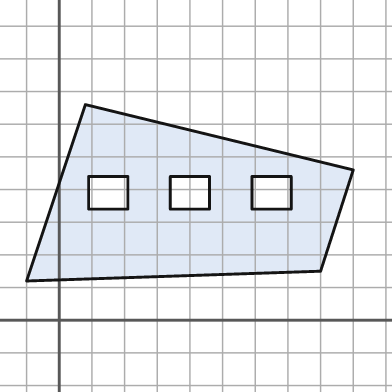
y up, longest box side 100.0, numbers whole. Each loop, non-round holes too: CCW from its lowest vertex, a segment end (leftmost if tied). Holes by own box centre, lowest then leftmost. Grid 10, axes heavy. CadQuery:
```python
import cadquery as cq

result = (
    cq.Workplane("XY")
    .moveTo(-10.0, 12.0)
    .lineTo(80.0, 15.0)
    .lineTo(90.0, 46.0)
    .lineTo(8.0, 66.0)
    .close()
    .moveTo(9.0, 34.0)
    .lineTo(21.0, 34.0)
    .lineTo(21.0, 44.0)
    .lineTo(9.0, 44.0)
    .close()
    .moveTo(34.0, 34.0)
    .lineTo(46.0, 34.0)
    .lineTo(46.0, 44.0)
    .lineTo(34.0, 44.0)
    .close()
    .moveTo(59.0, 34.0)
    .lineTo(71.0, 34.0)
    .lineTo(71.0, 44.0)
    .lineTo(59.0, 44.0)
    .close()
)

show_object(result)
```